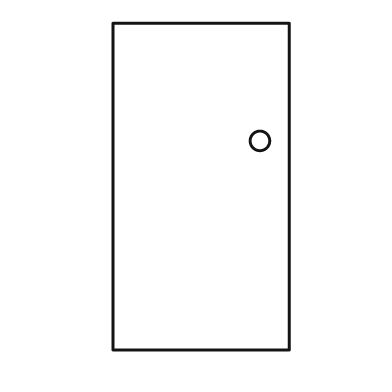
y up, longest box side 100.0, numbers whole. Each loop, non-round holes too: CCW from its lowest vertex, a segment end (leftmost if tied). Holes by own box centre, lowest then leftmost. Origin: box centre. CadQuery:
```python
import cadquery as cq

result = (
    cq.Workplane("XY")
    .moveTo(-27.0, -50.0)
    .lineTo(27.0, -50.0)
    .lineTo(27.0, 50.0)
    .lineTo(-27.0, 50.0)
    .close()
    .moveTo(18.0, 14.0)
    .circle(3.0)
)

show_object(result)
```